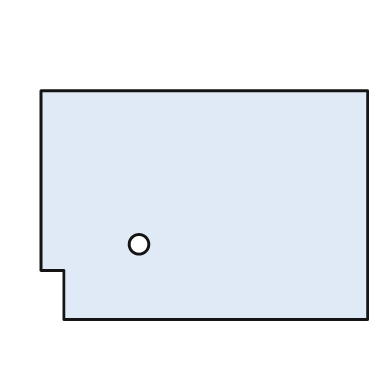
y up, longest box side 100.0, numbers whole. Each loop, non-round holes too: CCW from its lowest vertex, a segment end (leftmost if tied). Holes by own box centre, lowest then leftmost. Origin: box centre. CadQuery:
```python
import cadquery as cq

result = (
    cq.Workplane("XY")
    .moveTo(-43.0, -35.0)
    .lineTo(50.0, -35.0)
    .lineTo(50.0, 35.0)
    .lineTo(-50.0, 35.0)
    .lineTo(-50.0, -20.0)
    .lineTo(-43.0, -20.0)
    .close()
    .moveTo(-20.0, -12.0)
    .circle(3.0)
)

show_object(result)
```